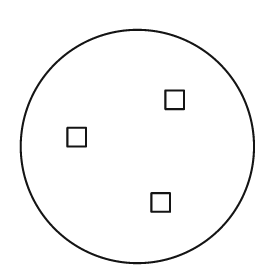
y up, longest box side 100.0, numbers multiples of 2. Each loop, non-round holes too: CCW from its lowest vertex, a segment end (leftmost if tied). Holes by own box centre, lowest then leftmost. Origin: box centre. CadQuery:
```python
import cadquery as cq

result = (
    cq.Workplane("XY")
    .moveTo(0.0, 0.0)
    .circle(50.0)
    .moveTo(6.0, -28.0)
    .lineTo(14.0, -28.0)
    .lineTo(14.0, -20.0)
    .lineTo(6.0, -20.0)
    .close()
    .moveTo(-30.0, 0.0)
    .lineTo(-22.0, 0.0)
    .lineTo(-22.0, 8.0)
    .lineTo(-30.0, 8.0)
    .close()
    .moveTo(12.0, 16.0)
    .lineTo(20.0, 16.0)
    .lineTo(20.0, 24.0)
    .lineTo(12.0, 24.0)
    .close()
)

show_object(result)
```